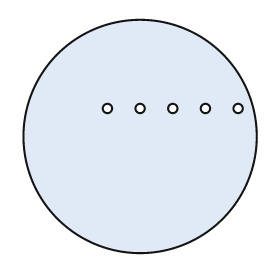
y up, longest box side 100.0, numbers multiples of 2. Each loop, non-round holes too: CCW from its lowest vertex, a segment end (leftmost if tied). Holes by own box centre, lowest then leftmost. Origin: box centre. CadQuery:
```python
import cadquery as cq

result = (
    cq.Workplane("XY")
    .moveTo(0.0, 0.0)
    .circle(50.0)
    .moveTo(-14.0, 12.0)
    .circle(2.0)
    .moveTo(0.0, 12.0)
    .circle(2.0)
    .moveTo(14.0, 12.0)
    .circle(2.0)
    .moveTo(28.0, 12.0)
    .circle(2.0)
    .moveTo(42.0, 12.0)
    .circle(2.0)
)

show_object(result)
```